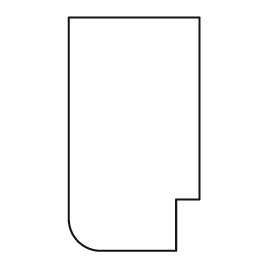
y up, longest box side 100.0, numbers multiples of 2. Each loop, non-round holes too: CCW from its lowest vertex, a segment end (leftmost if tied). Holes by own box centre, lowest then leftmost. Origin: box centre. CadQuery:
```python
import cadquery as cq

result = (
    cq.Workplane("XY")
    .moveTo(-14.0, -50.0)
    .lineTo(18.0, -50.0)
    .lineTo(18.0, -28.0)
    .lineTo(28.0, -28.0)
    .lineTo(28.0, 50.0)
    .lineTo(-28.0, 50.0)
    .lineTo(-28.0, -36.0)
    .threePointArc((-24.0, -46.0), (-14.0, -50.0))
    .close()
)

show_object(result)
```